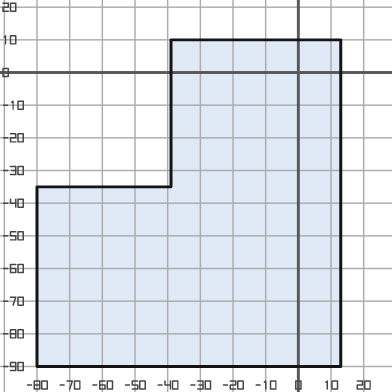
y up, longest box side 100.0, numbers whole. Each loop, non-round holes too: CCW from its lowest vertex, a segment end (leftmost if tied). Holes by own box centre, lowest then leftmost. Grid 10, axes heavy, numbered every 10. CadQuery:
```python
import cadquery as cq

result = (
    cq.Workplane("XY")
    .moveTo(-80.0, -90.0)
    .lineTo(13.0, -90.0)
    .lineTo(13.0, 10.0)
    .lineTo(-39.0, 10.0)
    .lineTo(-39.0, -35.0)
    .lineTo(-80.0, -35.0)
    .close()
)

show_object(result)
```